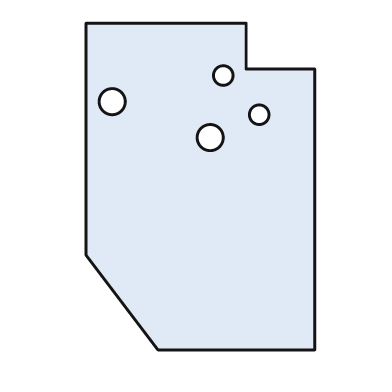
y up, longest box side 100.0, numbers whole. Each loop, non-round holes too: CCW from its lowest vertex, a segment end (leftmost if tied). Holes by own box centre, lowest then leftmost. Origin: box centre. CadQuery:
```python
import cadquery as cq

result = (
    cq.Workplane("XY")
    .moveTo(-13.0, -50.0)
    .lineTo(35.0, -50.0)
    .lineTo(35.0, 36.0)
    .lineTo(14.0, 36.0)
    .lineTo(14.0, 50.0)
    .lineTo(-35.0, 50.0)
    .lineTo(-35.0, -21.0)
    .close()
    .moveTo(3.0, 15.0)
    .circle(4.0)
    .moveTo(18.0, 22.0)
    .circle(3.0)
    .moveTo(-27.0, 26.0)
    .circle(4.0)
    .moveTo(7.0, 34.0)
    .circle(3.0)
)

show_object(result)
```